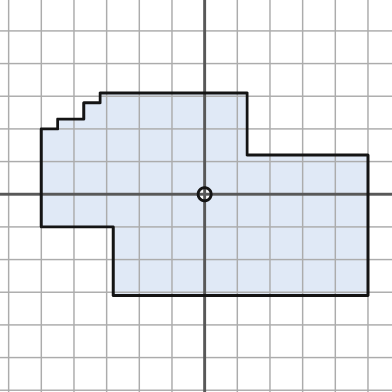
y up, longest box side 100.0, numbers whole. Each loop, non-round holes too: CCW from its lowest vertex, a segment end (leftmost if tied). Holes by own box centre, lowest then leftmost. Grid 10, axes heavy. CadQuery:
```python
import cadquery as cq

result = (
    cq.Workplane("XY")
    .moveTo(-28.0, -31.0)
    .lineTo(50.0, -31.0)
    .lineTo(50.0, 12.0)
    .lineTo(13.0, 12.0)
    .lineTo(13.0, 31.0)
    .lineTo(-32.0, 31.0)
    .lineTo(-32.0, 28.0)
    .lineTo(-37.0, 28.0)
    .lineTo(-37.0, 23.0)
    .lineTo(-45.0, 23.0)
    .lineTo(-45.0, 20.0)
    .lineTo(-50.0, 20.0)
    .lineTo(-50.0, -10.0)
    .lineTo(-28.0, -10.0)
    .close()
    .moveTo(0.0, 0.0)
    .circle(2.0)
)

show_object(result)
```